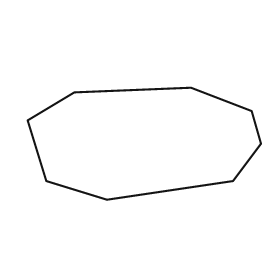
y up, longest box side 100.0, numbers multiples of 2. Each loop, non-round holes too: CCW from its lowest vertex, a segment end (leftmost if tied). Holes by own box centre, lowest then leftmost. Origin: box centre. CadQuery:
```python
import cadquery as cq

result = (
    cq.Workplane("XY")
    .moveTo(-16.0, -24.0)
    .lineTo(38.0, -16.0)
    .lineTo(50.0, 0.0)
    .lineTo(46.0, 14.0)
    .lineTo(20.0, 24.0)
    .lineTo(-30.0, 22.0)
    .lineTo(-50.0, 10.0)
    .lineTo(-42.0, -16.0)
    .close()
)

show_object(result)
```